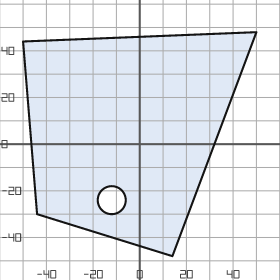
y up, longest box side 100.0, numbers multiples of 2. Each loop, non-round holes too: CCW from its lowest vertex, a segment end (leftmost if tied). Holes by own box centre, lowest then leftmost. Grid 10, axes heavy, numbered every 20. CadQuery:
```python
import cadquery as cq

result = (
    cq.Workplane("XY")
    .moveTo(14.0, -48.0)
    .lineTo(50.0, 48.0)
    .lineTo(-50.0, 44.0)
    .lineTo(-44.0, -30.0)
    .close()
    .moveTo(-12.0, -24.0)
    .circle(6.0)
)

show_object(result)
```